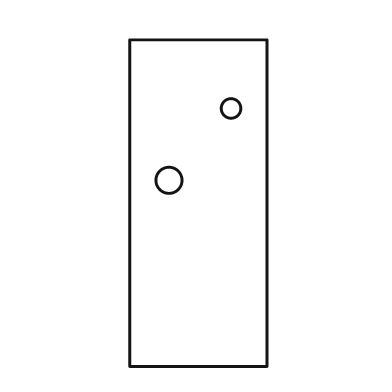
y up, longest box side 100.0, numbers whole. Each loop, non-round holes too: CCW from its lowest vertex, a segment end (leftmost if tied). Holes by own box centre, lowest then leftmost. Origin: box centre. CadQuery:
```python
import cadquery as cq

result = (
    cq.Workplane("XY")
    .moveTo(-21.0, -50.0)
    .lineTo(21.0, -50.0)
    .lineTo(21.0, 50.0)
    .lineTo(-21.0, 50.0)
    .close()
    .moveTo(-9.0, 7.0)
    .circle(4.0)
    .moveTo(10.0, 29.0)
    .circle(3.0)
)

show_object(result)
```